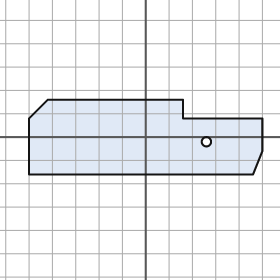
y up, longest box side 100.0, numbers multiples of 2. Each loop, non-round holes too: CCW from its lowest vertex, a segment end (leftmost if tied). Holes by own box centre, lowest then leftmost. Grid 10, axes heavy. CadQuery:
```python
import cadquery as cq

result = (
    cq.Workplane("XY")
    .moveTo(-50.0, -16.0)
    .lineTo(46.0, -16.0)
    .lineTo(50.0, -6.0)
    .lineTo(50.0, 8.0)
    .lineTo(16.0, 8.0)
    .lineTo(16.0, 16.0)
    .lineTo(-42.0, 16.0)
    .lineTo(-50.0, 8.0)
    .close()
    .moveTo(26.0, -2.0)
    .circle(2.0)
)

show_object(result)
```